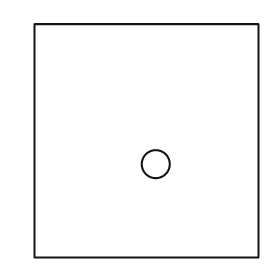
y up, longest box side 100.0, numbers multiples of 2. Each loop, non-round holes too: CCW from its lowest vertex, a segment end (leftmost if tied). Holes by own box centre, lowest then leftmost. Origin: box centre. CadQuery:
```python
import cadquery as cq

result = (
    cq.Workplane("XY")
    .moveTo(-48.0, -50.0)
    .lineTo(48.0, -50.0)
    .lineTo(48.0, 50.0)
    .lineTo(-48.0, 50.0)
    .close()
    .moveTo(4.0, -10.0)
    .circle(6.0)
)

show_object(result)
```